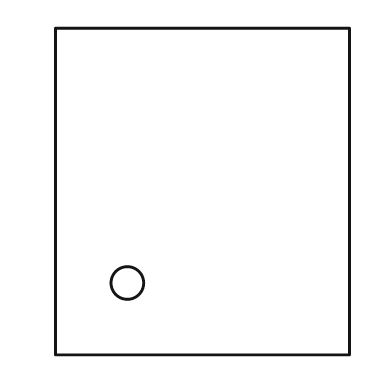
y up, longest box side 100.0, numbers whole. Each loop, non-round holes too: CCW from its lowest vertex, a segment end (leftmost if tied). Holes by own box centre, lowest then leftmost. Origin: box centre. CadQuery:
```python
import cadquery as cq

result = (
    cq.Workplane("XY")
    .moveTo(-45.0, -50.0)
    .lineTo(45.0, -50.0)
    .lineTo(45.0, 50.0)
    .lineTo(-45.0, 50.0)
    .close()
    .moveTo(-23.0, -28.0)
    .circle(5.0)
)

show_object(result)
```